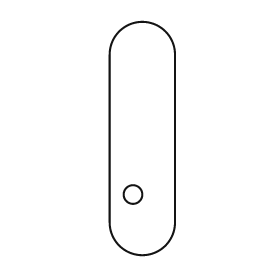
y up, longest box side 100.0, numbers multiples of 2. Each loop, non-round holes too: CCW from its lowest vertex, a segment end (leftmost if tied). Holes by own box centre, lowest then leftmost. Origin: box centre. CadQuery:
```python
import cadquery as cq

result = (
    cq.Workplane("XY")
    .moveTo(-14.0, -36.0)
    .threePointArc((0.0, -50.0), (14.0, -36.0))
    .lineTo(14.0, 36.0)
    .threePointArc((0.0, 50.0), (-14.0, 36.0))
    .close()
    .moveTo(-4.0, -24.0)
    .circle(4.0)
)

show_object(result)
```